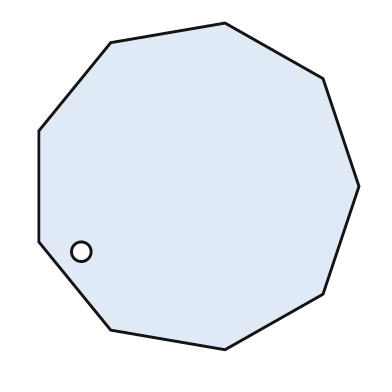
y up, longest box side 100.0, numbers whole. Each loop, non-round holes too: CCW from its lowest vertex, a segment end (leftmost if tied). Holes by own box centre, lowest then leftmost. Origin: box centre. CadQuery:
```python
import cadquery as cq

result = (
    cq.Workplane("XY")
    .moveTo(8.0, -50.0)
    .lineTo(38.0, -33.0)
    .lineTo(49.0, 0.0)
    .lineTo(38.0, 33.0)
    .lineTo(8.0, 50.0)
    .lineTo(-27.0, 44.0)
    .lineTo(-49.0, 17.0)
    .lineTo(-49.0, -17.0)
    .lineTo(-27.0, -44.0)
    .close()
    .moveTo(-36.0, -20.0)
    .circle(3.0)
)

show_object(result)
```